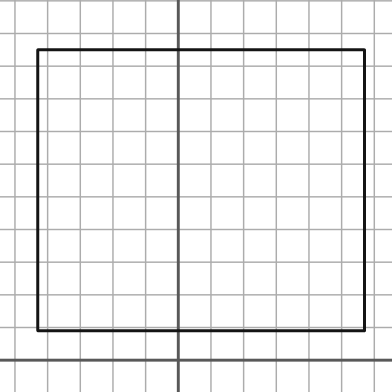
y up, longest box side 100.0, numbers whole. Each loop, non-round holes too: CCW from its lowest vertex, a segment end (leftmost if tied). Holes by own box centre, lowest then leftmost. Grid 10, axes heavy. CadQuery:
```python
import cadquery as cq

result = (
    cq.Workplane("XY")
    .moveTo(-43.0, 9.0)
    .lineTo(57.0, 9.0)
    .lineTo(57.0, 95.0)
    .lineTo(-43.0, 95.0)
    .close()
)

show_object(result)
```